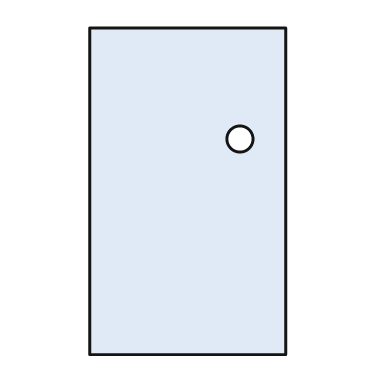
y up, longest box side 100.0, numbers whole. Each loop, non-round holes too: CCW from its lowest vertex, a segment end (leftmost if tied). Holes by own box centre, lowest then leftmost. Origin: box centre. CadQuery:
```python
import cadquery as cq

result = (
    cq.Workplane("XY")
    .moveTo(-30.0, -50.0)
    .lineTo(30.0, -50.0)
    .lineTo(30.0, 50.0)
    .lineTo(-30.0, 50.0)
    .close()
    .moveTo(16.0, 16.0)
    .circle(4.0)
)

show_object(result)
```